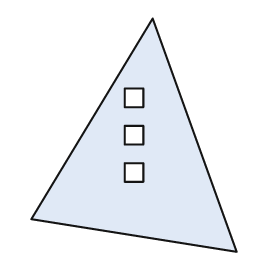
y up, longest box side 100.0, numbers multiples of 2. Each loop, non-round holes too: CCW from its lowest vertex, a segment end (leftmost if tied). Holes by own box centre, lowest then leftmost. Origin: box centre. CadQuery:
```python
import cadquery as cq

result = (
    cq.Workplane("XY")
    .moveTo(44.0, -50.0)
    .lineTo(8.0, 50.0)
    .lineTo(-44.0, -36.0)
    .close()
    .moveTo(-4.0, -20.0)
    .lineTo(4.0, -20.0)
    .lineTo(4.0, -12.0)
    .lineTo(-4.0, -12.0)
    .close()
    .moveTo(-4.0, -4.0)
    .lineTo(4.0, -4.0)
    .lineTo(4.0, 4.0)
    .lineTo(-4.0, 4.0)
    .close()
    .moveTo(-4.0, 12.0)
    .lineTo(4.0, 12.0)
    .lineTo(4.0, 20.0)
    .lineTo(-4.0, 20.0)
    .close()
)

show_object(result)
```